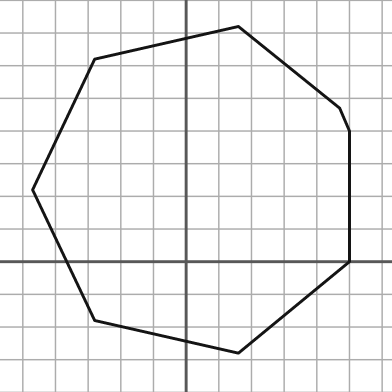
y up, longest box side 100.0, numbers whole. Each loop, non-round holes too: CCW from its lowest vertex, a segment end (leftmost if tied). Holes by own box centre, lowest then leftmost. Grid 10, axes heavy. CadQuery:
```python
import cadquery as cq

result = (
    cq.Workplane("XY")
    .moveTo(16.0, -28.0)
    .lineTo(50.0, 0.0)
    .lineTo(50.0, 40.0)
    .lineTo(47.0, 47.0)
    .lineTo(16.0, 72.0)
    .lineTo(-28.0, 62.0)
    .lineTo(-47.0, 22.0)
    .lineTo(-28.0, -18.0)
    .close()
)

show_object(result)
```